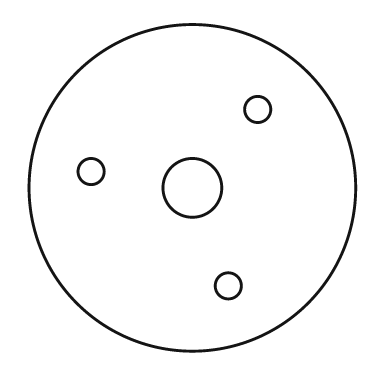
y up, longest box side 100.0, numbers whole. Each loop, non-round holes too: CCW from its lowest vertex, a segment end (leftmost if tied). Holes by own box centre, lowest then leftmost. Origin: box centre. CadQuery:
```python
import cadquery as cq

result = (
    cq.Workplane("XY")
    .moveTo(0.0, 0.0)
    .circle(50.0)
    .moveTo(11.0, -30.0)
    .circle(4.0)
    .moveTo(0.0, 0.0)
    .circle(9.0)
    .moveTo(-31.0, 5.0)
    .circle(4.0)
    .moveTo(20.0, 24.0)
    .circle(4.0)
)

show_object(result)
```